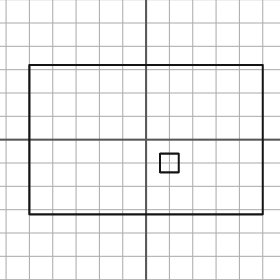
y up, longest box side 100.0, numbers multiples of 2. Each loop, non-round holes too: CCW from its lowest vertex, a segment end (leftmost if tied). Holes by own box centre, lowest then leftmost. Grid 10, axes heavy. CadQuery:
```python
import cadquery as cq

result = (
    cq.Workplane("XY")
    .moveTo(-50.0, -32.0)
    .lineTo(50.0, -32.0)
    .lineTo(50.0, 32.0)
    .lineTo(-50.0, 32.0)
    .close()
    .moveTo(6.0, -14.0)
    .lineTo(14.0, -14.0)
    .lineTo(14.0, -6.0)
    .lineTo(6.0, -6.0)
    .close()
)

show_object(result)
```